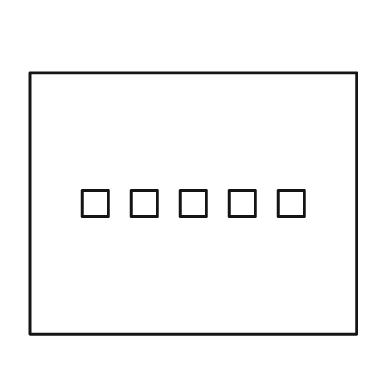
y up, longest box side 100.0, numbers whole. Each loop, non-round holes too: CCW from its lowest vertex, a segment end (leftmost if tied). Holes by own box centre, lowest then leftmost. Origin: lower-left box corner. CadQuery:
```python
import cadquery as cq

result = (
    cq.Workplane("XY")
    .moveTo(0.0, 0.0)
    .lineTo(100.0, 0.0)
    .lineTo(100.0, 80.0)
    .lineTo(0.0, 80.0)
    .close()
    .moveTo(16.0, 36.0)
    .lineTo(24.0, 36.0)
    .lineTo(24.0, 44.0)
    .lineTo(16.0, 44.0)
    .close()
    .moveTo(31.0, 36.0)
    .lineTo(39.0, 36.0)
    .lineTo(39.0, 44.0)
    .lineTo(31.0, 44.0)
    .close()
    .moveTo(46.0, 36.0)
    .lineTo(54.0, 36.0)
    .lineTo(54.0, 44.0)
    .lineTo(46.0, 44.0)
    .close()
    .moveTo(61.0, 36.0)
    .lineTo(69.0, 36.0)
    .lineTo(69.0, 44.0)
    .lineTo(61.0, 44.0)
    .close()
    .moveTo(76.0, 36.0)
    .lineTo(84.0, 36.0)
    .lineTo(84.0, 44.0)
    .lineTo(76.0, 44.0)
    .close()
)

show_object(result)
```